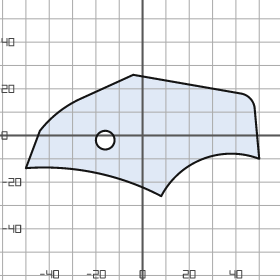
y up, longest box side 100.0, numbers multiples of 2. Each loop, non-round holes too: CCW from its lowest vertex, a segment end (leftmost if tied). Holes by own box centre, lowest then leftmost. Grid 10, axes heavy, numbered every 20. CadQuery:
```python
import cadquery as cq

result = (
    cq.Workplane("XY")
    .moveTo(8.0, -26.0)
    .threePointArc((26.0, -10.0), (50.0, -10.0))
    .lineTo(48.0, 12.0)
    .threePointArc((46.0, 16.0), (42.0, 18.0))
    .lineTo(-4.0, 26.0)
    .lineTo(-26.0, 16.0)
    .threePointArc((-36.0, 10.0), (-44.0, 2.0))
    .lineTo(-50.0, -14.0)
    .threePointArc((-20.0, -16.0), (8.0, -26.0))
    .close()
    .moveTo(-16.0, -2.0)
    .circle(4.0)
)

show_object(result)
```